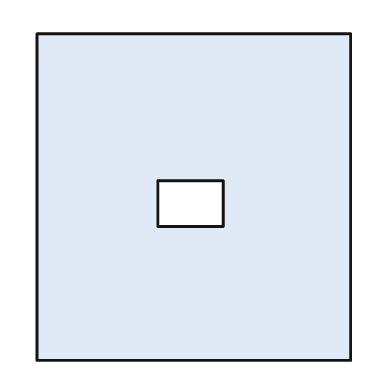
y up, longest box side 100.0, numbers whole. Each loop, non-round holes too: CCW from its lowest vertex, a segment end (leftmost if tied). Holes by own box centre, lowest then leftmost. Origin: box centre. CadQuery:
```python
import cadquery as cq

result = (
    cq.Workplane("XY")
    .moveTo(-48.0, -50.0)
    .lineTo(48.0, -50.0)
    .lineTo(48.0, 50.0)
    .lineTo(-48.0, 50.0)
    .close()
    .moveTo(-11.0, -9.0)
    .lineTo(9.0, -9.0)
    .lineTo(9.0, 5.0)
    .lineTo(-11.0, 5.0)
    .close()
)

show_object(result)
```